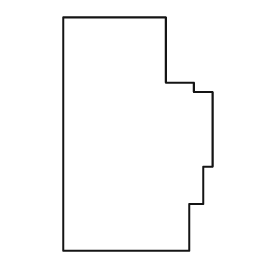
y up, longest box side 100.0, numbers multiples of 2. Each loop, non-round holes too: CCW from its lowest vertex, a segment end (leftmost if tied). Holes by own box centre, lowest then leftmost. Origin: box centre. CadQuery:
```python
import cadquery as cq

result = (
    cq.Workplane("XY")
    .moveTo(-32.0, -50.0)
    .lineTo(22.0, -50.0)
    .lineTo(22.0, -30.0)
    .lineTo(28.0, -30.0)
    .lineTo(28.0, -14.0)
    .lineTo(32.0, -14.0)
    .lineTo(32.0, 18.0)
    .lineTo(24.0, 18.0)
    .lineTo(24.0, 22.0)
    .lineTo(12.0, 22.0)
    .lineTo(12.0, 50.0)
    .lineTo(-32.0, 50.0)
    .close()
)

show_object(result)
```